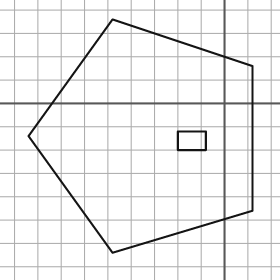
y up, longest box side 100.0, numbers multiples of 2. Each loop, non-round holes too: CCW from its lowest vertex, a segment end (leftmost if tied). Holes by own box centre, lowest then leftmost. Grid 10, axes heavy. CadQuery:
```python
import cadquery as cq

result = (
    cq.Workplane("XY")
    .moveTo(-48.0, -64.0)
    .lineTo(12.0, -46.0)
    .lineTo(12.0, 16.0)
    .lineTo(-48.0, 36.0)
    .lineTo(-84.0, -14.0)
    .close()
    .moveTo(-20.0, -20.0)
    .lineTo(-8.0, -20.0)
    .lineTo(-8.0, -12.0)
    .lineTo(-20.0, -12.0)
    .close()
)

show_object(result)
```